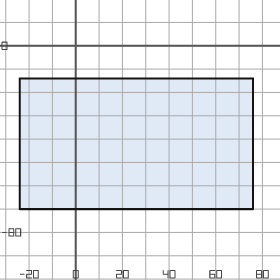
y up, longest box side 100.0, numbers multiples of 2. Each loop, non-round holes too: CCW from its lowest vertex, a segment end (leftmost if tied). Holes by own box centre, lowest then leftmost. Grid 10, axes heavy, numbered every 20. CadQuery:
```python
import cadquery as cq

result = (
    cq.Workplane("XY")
    .moveTo(-24.0, -70.0)
    .lineTo(76.0, -70.0)
    .lineTo(76.0, -14.0)
    .lineTo(-24.0, -14.0)
    .close()
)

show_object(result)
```